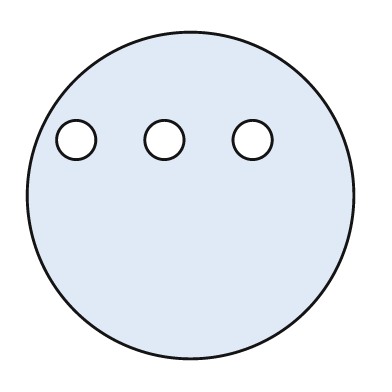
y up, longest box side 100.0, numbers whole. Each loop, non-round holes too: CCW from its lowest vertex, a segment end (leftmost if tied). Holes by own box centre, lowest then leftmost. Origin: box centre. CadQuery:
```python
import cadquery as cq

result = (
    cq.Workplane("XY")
    .moveTo(0.0, 0.0)
    .circle(50.0)
    .moveTo(-35.0, 17.0)
    .circle(6.0)
    .moveTo(-8.0, 17.0)
    .circle(6.0)
    .moveTo(19.0, 17.0)
    .circle(6.0)
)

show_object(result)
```